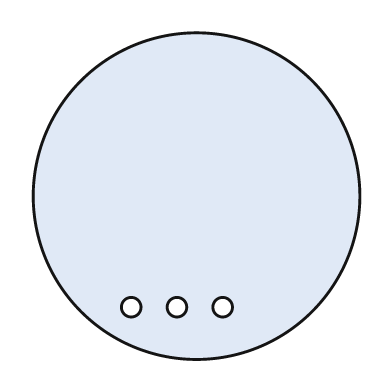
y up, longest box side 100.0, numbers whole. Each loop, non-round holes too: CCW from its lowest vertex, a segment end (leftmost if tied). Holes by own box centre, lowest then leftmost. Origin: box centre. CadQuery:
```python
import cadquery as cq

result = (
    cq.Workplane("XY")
    .moveTo(0.0, 0.0)
    .circle(50.0)
    .moveTo(-20.0, -34.0)
    .circle(3.0)
    .moveTo(-6.0, -34.0)
    .circle(3.0)
    .moveTo(8.0, -34.0)
    .circle(3.0)
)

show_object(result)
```